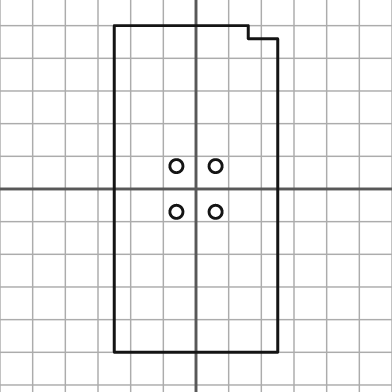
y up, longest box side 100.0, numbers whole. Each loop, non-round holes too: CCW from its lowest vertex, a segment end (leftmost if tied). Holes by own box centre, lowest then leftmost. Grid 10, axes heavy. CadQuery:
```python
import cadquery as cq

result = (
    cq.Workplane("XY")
    .moveTo(-25.0, -50.0)
    .lineTo(25.0, -50.0)
    .lineTo(25.0, 46.0)
    .lineTo(16.0, 46.0)
    .lineTo(16.0, 50.0)
    .lineTo(-25.0, 50.0)
    .close()
    .moveTo(-6.0, -7.0)
    .circle(2.0)
    .moveTo(6.0, -7.0)
    .circle(2.0)
    .moveTo(-6.0, 7.0)
    .circle(2.0)
    .moveTo(6.0, 7.0)
    .circle(2.0)
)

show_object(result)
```